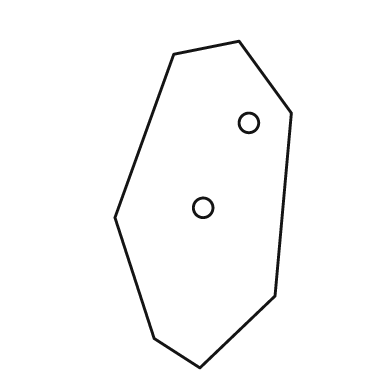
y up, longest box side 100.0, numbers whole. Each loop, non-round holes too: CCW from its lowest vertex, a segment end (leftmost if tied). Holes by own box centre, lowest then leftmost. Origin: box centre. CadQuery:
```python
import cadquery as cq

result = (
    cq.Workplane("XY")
    .moveTo(-1.0, -50.0)
    .lineTo(22.0, -28.0)
    .lineTo(27.0, 28.0)
    .lineTo(11.0, 50.0)
    .lineTo(-9.0, 46.0)
    .lineTo(-27.0, -4.0)
    .lineTo(-15.0, -41.0)
    .close()
    .moveTo(0.0, -1.0)
    .circle(3.0)
    .moveTo(14.0, 25.0)
    .circle(3.0)
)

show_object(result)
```